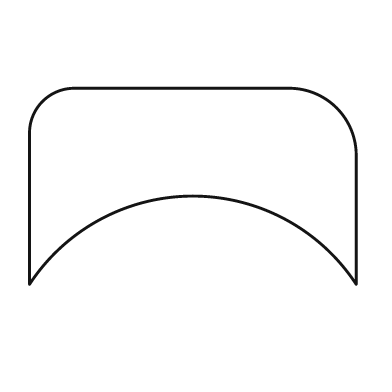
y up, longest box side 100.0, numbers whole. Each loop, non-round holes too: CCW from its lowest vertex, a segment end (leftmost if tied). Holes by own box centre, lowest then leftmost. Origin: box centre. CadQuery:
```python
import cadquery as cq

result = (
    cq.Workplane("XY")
    .moveTo(-50.0, -30.0)
    .threePointArc((0.0, -3.0), (50.0, -30.0))
    .lineTo(50.0, 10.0)
    .threePointArc((44.0, 24.0), (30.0, 30.0))
    .lineTo(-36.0, 30.0)
    .threePointArc((-46.0, 26.0), (-50.0, 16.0))
    .close()
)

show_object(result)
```